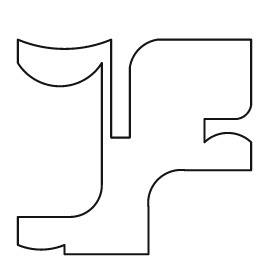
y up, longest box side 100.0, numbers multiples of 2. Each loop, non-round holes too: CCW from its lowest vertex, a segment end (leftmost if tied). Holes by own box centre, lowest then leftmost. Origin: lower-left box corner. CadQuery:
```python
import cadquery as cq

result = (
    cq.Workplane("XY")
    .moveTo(20.0, 0.0)
    .lineTo(56.0, 0.0)
    .lineTo(56.0, 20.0)
    .threePointArc((60.0, 32.0), (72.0, 36.0))
    .lineTo(100.0, 36.0)
    .lineTo(100.0, 48.0)
    .threePointArc((90.0, 52.0), (80.0, 48.0))
    .lineTo(80.0, 58.0)
    .lineTo(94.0, 58.0)
    .threePointArc((98.0, 60.0), (100.0, 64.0))
    .lineTo(100.0, 92.0)
    .lineTo(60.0, 92.0)
    .threePointArc((52.0, 88.0), (48.0, 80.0))
    .lineTo(48.0, 50.0)
    .lineTo(40.0, 50.0)
    .lineTo(40.0, 92.0)
    .threePointArc((20.0, 88.0), (0.0, 92.0))
    .lineTo(0.0, 82.0)
    .threePointArc((18.0, 72.0), (36.0, 82.0))
    .lineTo(36.0, 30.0)
    .threePointArc((32.0, 20.0), (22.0, 16.0))
    .lineTo(0.0, 16.0)
    .lineTo(0.0, 4.0)
    .threePointArc((10.0, 2.0), (20.0, 4.0))
    .close()
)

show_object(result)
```